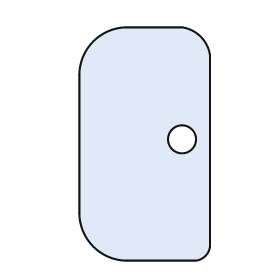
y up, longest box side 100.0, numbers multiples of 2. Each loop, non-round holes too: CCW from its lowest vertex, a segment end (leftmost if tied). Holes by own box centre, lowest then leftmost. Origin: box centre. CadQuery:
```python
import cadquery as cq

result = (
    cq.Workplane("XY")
    .moveTo(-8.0, -50.0)
    .lineTo(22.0, -50.0)
    .threePointArc((26.0, -48.0), (28.0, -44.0))
    .lineTo(28.0, 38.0)
    .threePointArc((24.0, 46.0), (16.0, 50.0))
    .lineTo(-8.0, 50.0)
    .threePointArc((-22.0, 44.0), (-28.0, 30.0))
    .lineTo(-28.0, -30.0)
    .threePointArc((-22.0, -44.0), (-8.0, -50.0))
    .close()
    .moveTo(16.0, 2.0)
    .circle(6.0)
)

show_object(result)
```